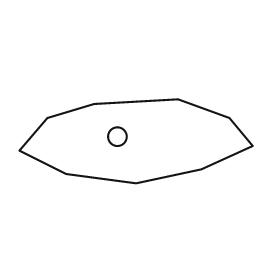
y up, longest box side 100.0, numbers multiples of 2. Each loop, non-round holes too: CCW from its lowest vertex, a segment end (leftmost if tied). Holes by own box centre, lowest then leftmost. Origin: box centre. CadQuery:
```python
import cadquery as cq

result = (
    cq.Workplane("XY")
    .moveTo(0.0, -18.0)
    .lineTo(28.0, -12.0)
    .lineTo(50.0, -2.0)
    .lineTo(40.0, 10.0)
    .lineTo(18.0, 18.0)
    .lineTo(-18.0, 16.0)
    .lineTo(-38.0, 10.0)
    .lineTo(-50.0, -4.0)
    .lineTo(-30.0, -14.0)
    .close()
    .moveTo(-8.0, 2.0)
    .circle(4.0)
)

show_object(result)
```